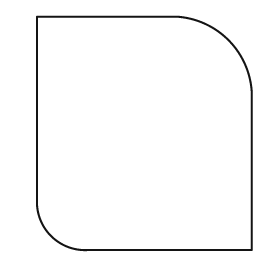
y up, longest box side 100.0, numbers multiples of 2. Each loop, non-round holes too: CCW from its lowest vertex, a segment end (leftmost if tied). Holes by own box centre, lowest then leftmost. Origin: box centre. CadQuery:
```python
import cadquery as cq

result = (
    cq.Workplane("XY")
    .moveTo(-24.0, -50.0)
    .lineTo(46.0, -50.0)
    .lineTo(46.0, 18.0)
    .threePointArc((36.0, 40.0), (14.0, 50.0))
    .lineTo(-46.0, 50.0)
    .lineTo(-46.0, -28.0)
    .threePointArc((-40.0, -44.0), (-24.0, -50.0))
    .close()
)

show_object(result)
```